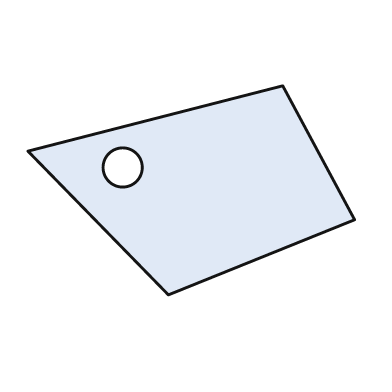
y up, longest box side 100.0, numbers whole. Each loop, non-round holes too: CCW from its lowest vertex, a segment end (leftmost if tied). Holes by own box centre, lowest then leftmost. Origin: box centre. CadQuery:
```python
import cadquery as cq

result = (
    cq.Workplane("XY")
    .moveTo(-7.0, -32.0)
    .lineTo(50.0, -9.0)
    .lineTo(28.0, 32.0)
    .lineTo(-50.0, 12.0)
    .close()
    .moveTo(-21.0, 7.0)
    .circle(6.0)
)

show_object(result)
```